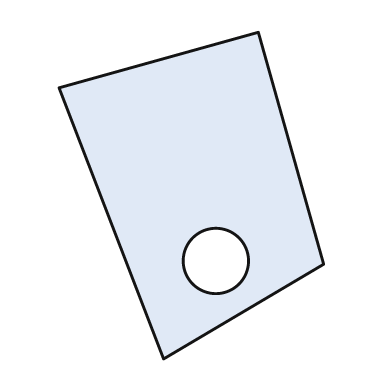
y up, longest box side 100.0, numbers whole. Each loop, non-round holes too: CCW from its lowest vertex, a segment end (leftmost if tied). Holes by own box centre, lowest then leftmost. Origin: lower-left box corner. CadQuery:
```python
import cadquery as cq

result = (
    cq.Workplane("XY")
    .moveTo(32.0, 0.0)
    .lineTo(81.0, 29.0)
    .lineTo(61.0, 100.0)
    .lineTo(0.0, 83.0)
    .close()
    .moveTo(48.0, 30.0)
    .circle(10.0)
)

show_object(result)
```